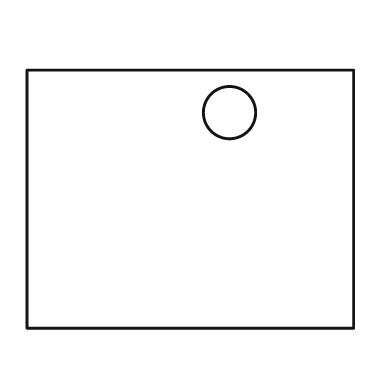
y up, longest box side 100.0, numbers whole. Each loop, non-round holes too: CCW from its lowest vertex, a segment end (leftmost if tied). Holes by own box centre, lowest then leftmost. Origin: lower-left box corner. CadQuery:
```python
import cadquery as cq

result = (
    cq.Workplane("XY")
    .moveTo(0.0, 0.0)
    .lineTo(100.0, 0.0)
    .lineTo(100.0, 79.0)
    .lineTo(0.0, 79.0)
    .close()
    .moveTo(62.0, 66.0)
    .circle(8.0)
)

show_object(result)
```